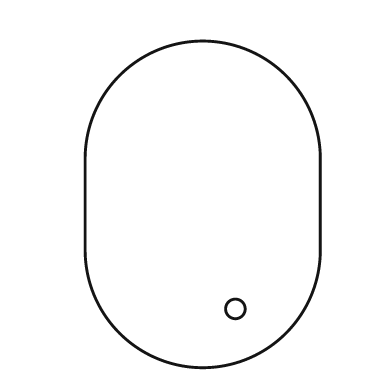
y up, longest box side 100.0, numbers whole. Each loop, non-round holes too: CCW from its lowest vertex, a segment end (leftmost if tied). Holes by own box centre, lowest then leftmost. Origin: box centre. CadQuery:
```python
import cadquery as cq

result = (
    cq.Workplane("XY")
    .moveTo(-36.0, -14.0)
    .threePointArc((0.0, -50.0), (36.0, -14.0))
    .lineTo(36.0, 14.0)
    .threePointArc((0.0, 50.0), (-36.0, 14.0))
    .close()
    .moveTo(10.0, -32.0)
    .circle(3.0)
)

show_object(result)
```